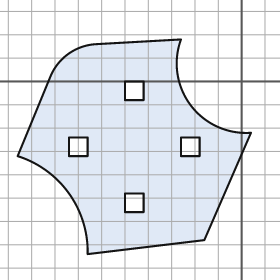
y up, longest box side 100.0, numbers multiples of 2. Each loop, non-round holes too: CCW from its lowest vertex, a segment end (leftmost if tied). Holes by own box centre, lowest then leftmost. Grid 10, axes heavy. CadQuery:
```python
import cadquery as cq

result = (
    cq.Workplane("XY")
    .moveTo(-66.0, -74.0)
    .lineTo(-16.0, -68.0)
    .lineTo(4.0, -22.0)
    .threePointArc((-22.0, -10.0), (-26.0, 18.0))
    .lineTo(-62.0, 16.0)
    .threePointArc((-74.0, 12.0), (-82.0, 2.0))
    .lineTo(-96.0, -32.0)
    .threePointArc((-74.0, -48.0), (-66.0, -74.0))
    .close()
    .moveTo(-50.0, -56.0)
    .lineTo(-42.0, -56.0)
    .lineTo(-42.0, -48.0)
    .lineTo(-50.0, -48.0)
    .close()
    .moveTo(-74.0, -32.0)
    .lineTo(-66.0, -32.0)
    .lineTo(-66.0, -24.0)
    .lineTo(-74.0, -24.0)
    .close()
    .moveTo(-26.0, -32.0)
    .lineTo(-18.0, -32.0)
    .lineTo(-18.0, -24.0)
    .lineTo(-26.0, -24.0)
    .close()
    .moveTo(-50.0, -8.0)
    .lineTo(-42.0, -8.0)
    .lineTo(-42.0, 0.0)
    .lineTo(-50.0, 0.0)
    .close()
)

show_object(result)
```